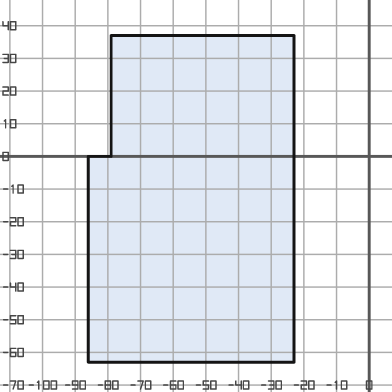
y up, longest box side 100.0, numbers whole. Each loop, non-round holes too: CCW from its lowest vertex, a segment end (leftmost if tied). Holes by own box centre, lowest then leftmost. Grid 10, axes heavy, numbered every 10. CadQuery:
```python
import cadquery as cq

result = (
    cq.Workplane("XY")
    .moveTo(-86.0, -63.0)
    .lineTo(-23.0, -63.0)
    .lineTo(-23.0, 37.0)
    .lineTo(-79.0, 37.0)
    .lineTo(-79.0, 0.0)
    .lineTo(-86.0, 0.0)
    .close()
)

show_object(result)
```